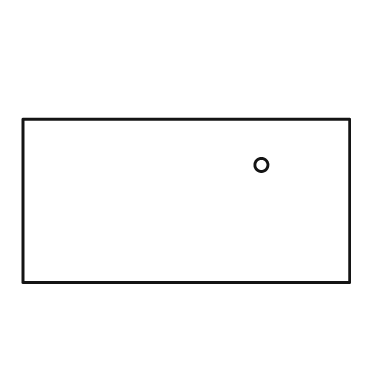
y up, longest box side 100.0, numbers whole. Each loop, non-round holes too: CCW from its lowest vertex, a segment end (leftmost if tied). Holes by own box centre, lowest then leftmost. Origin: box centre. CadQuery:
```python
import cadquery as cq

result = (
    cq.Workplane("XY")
    .moveTo(-50.0, -25.0)
    .lineTo(50.0, -25.0)
    .lineTo(50.0, 25.0)
    .lineTo(-50.0, 25.0)
    .close()
    .moveTo(23.0, 11.0)
    .circle(2.0)
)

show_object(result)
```